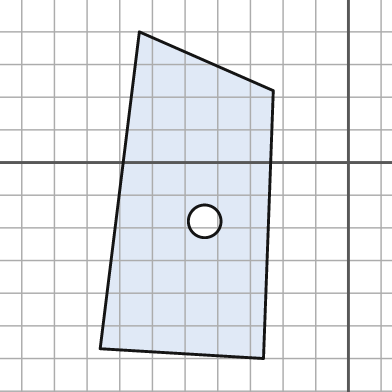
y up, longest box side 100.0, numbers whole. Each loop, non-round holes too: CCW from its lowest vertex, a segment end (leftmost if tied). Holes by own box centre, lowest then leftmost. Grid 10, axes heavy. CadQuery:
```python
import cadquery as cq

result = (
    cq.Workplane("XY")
    .moveTo(-26.0, -60.0)
    .lineTo(-23.0, 22.0)
    .lineTo(-64.0, 40.0)
    .lineTo(-76.0, -57.0)
    .close()
    .moveTo(-44.0, -18.0)
    .circle(5.0)
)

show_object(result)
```